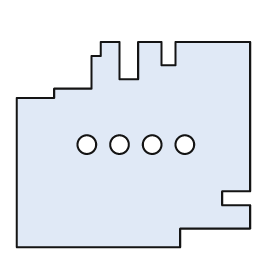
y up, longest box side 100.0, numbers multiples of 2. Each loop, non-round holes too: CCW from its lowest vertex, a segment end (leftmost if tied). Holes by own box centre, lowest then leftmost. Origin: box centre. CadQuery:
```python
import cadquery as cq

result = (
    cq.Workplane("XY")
    .moveTo(-50.0, -44.0)
    .lineTo(20.0, -44.0)
    .lineTo(20.0, -36.0)
    .lineTo(50.0, -36.0)
    .lineTo(50.0, -26.0)
    .lineTo(38.0, -26.0)
    .lineTo(38.0, -20.0)
    .lineTo(50.0, -20.0)
    .lineTo(50.0, 44.0)
    .lineTo(18.0, 44.0)
    .lineTo(18.0, 34.0)
    .lineTo(12.0, 34.0)
    .lineTo(12.0, 44.0)
    .lineTo(2.0, 44.0)
    .lineTo(2.0, 28.0)
    .lineTo(-6.0, 28.0)
    .lineTo(-6.0, 44.0)
    .lineTo(-14.0, 44.0)
    .lineTo(-14.0, 38.0)
    .lineTo(-18.0, 38.0)
    .lineTo(-18.0, 24.0)
    .lineTo(-34.0, 24.0)
    .lineTo(-34.0, 20.0)
    .lineTo(-50.0, 20.0)
    .close()
    .moveTo(-20.0, 0.0)
    .circle(4.0)
    .moveTo(-6.0, 0.0)
    .circle(4.0)
    .moveTo(8.0, 0.0)
    .circle(4.0)
    .moveTo(22.0, 0.0)
    .circle(4.0)
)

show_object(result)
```